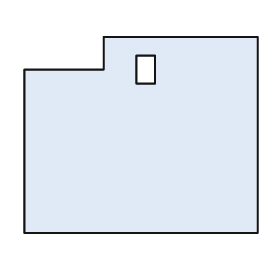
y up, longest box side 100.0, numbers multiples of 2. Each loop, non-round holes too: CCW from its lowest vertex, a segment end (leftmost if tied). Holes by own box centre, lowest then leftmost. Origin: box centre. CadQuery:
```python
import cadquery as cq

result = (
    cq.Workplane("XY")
    .moveTo(-50.0, -42.0)
    .lineTo(50.0, -42.0)
    .lineTo(50.0, 42.0)
    .lineTo(-16.0, 42.0)
    .lineTo(-16.0, 28.0)
    .lineTo(-50.0, 28.0)
    .close()
    .moveTo(-2.0, 22.0)
    .lineTo(6.0, 22.0)
    .lineTo(6.0, 34.0)
    .lineTo(-2.0, 34.0)
    .close()
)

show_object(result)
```